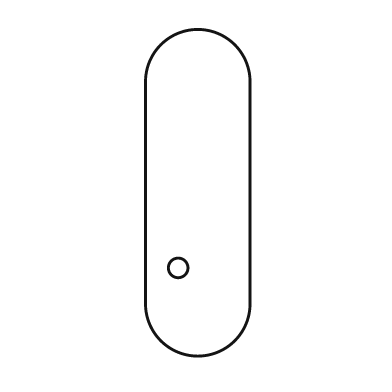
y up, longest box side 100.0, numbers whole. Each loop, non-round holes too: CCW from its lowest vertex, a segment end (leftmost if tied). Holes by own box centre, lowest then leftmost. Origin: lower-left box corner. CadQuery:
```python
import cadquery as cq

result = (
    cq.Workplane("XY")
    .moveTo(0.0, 16.0)
    .threePointArc((16.0, 0.0), (32.0, 16.0))
    .lineTo(32.0, 84.0)
    .threePointArc((16.0, 100.0), (0.0, 84.0))
    .close()
    .moveTo(10.0, 27.0)
    .circle(3.0)
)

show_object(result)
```